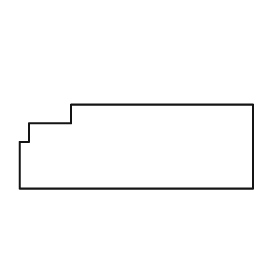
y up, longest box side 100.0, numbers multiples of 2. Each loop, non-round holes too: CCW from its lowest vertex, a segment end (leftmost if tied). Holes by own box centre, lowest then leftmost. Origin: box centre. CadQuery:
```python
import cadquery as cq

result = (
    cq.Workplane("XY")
    .moveTo(-50.0, -18.0)
    .lineTo(50.0, -18.0)
    .lineTo(50.0, 18.0)
    .lineTo(-28.0, 18.0)
    .lineTo(-28.0, 10.0)
    .lineTo(-46.0, 10.0)
    .lineTo(-46.0, 2.0)
    .lineTo(-50.0, 2.0)
    .close()
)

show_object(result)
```